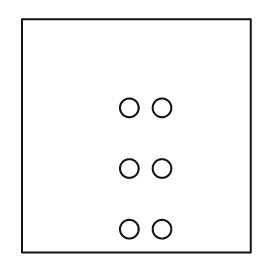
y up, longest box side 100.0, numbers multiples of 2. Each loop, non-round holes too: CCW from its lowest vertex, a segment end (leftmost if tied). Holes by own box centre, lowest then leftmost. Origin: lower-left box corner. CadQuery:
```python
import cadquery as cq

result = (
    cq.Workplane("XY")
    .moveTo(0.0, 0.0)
    .lineTo(98.0, 0.0)
    .lineTo(98.0, 100.0)
    .lineTo(0.0, 100.0)
    .close()
    .moveTo(46.0, 10.0)
    .circle(4.0)
    .moveTo(60.0, 10.0)
    .circle(4.0)
    .moveTo(46.0, 36.0)
    .circle(4.0)
    .moveTo(60.0, 36.0)
    .circle(4.0)
    .moveTo(46.0, 62.0)
    .circle(4.0)
    .moveTo(60.0, 62.0)
    .circle(4.0)
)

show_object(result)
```